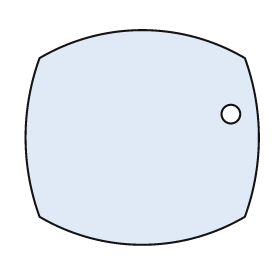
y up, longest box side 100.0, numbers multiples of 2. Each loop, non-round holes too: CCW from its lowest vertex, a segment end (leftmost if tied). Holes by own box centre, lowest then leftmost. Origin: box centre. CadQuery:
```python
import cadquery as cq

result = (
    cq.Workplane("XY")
    .moveTo(-44.0, -34.0)
    .threePointArc((0.0, -46.0), (44.0, -34.0))
    .threePointArc((50.0, 0.0), (44.0, 34.0))
    .threePointArc((0.0, 46.0), (-44.0, 34.0))
    .threePointArc((-50.0, 0.0), (-44.0, -34.0))
    .close()
    .moveTo(38.0, 10.0)
    .circle(4.0)
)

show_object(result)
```